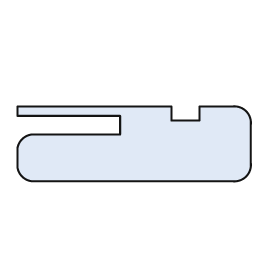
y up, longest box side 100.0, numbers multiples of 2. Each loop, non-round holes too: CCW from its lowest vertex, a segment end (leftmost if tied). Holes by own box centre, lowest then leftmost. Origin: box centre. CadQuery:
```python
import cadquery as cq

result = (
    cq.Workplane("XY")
    .moveTo(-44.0, -16.0)
    .lineTo(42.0, -16.0)
    .threePointArc((48.0, -14.0), (50.0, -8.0))
    .lineTo(50.0, 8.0)
    .threePointArc((48.0, 14.0), (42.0, 16.0))
    .lineTo(28.0, 16.0)
    .lineTo(28.0, 10.0)
    .lineTo(16.0, 10.0)
    .lineTo(16.0, 16.0)
    .lineTo(-50.0, 16.0)
    .lineTo(-50.0, 12.0)
    .lineTo(-6.0, 12.0)
    .lineTo(-6.0, 4.0)
    .lineTo(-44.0, 4.0)
    .threePointArc((-48.0, 2.0), (-50.0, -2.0))
    .lineTo(-50.0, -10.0)
    .threePointArc((-48.0, -14.0), (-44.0, -16.0))
    .close()
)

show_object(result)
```